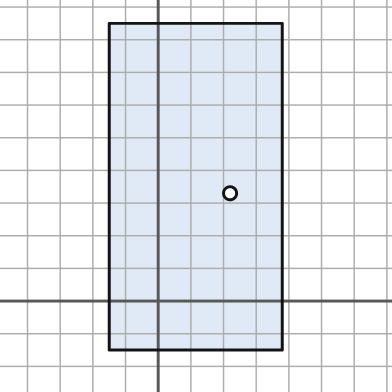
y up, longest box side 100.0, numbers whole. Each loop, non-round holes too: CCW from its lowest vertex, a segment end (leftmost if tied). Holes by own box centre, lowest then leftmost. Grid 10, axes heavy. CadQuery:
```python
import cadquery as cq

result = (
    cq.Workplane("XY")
    .moveTo(-15.0, -15.0)
    .lineTo(38.0, -15.0)
    .lineTo(38.0, 85.0)
    .lineTo(-15.0, 85.0)
    .close()
    .moveTo(22.0, 33.0)
    .circle(2.0)
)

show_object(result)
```